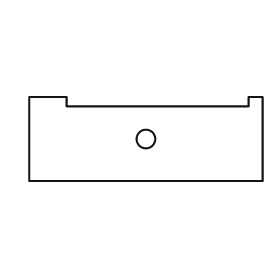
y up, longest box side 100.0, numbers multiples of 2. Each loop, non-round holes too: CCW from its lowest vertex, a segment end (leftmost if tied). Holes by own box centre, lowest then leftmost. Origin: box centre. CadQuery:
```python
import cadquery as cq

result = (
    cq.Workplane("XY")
    .moveTo(-50.0, -18.0)
    .lineTo(50.0, -18.0)
    .lineTo(50.0, 18.0)
    .lineTo(44.0, 18.0)
    .lineTo(44.0, 14.0)
    .lineTo(-34.0, 14.0)
    .lineTo(-34.0, 18.0)
    .lineTo(-50.0, 18.0)
    .close()
    .moveTo(0.0, 0.0)
    .circle(4.0)
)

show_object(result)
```